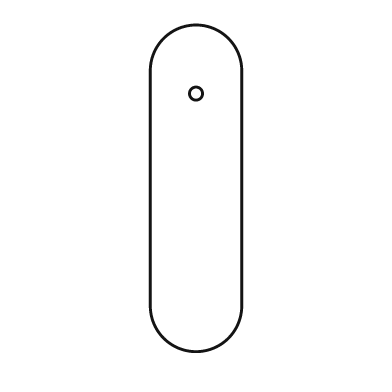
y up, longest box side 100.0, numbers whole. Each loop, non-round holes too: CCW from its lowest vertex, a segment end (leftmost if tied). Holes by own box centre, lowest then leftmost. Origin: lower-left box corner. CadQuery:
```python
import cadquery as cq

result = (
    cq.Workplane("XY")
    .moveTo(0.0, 14.0)
    .threePointArc((14.0, 0.0), (28.0, 14.0))
    .lineTo(28.0, 86.0)
    .threePointArc((14.0, 100.0), (0.0, 86.0))
    .close()
    .moveTo(14.0, 79.0)
    .circle(2.0)
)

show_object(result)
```